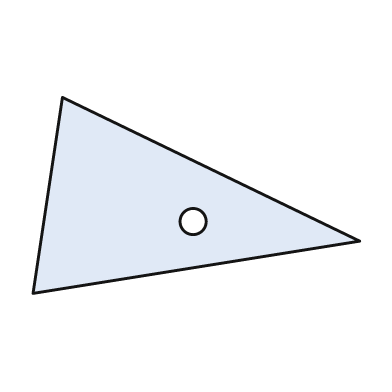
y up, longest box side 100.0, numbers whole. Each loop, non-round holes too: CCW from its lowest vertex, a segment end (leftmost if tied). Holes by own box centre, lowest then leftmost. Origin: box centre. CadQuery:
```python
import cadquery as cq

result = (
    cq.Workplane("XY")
    .moveTo(-50.0, -30.0)
    .lineTo(50.0, -14.0)
    .lineTo(-41.0, 30.0)
    .close()
    .moveTo(-1.0, -8.0)
    .circle(4.0)
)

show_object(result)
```